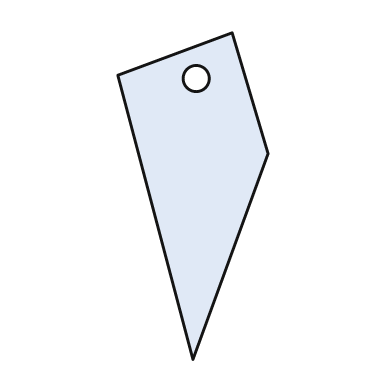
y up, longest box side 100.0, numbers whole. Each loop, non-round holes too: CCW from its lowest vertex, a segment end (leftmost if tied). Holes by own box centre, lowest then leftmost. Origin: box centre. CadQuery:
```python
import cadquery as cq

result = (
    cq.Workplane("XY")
    .moveTo(0.0, -50.0)
    .lineTo(23.0, 13.0)
    .lineTo(12.0, 50.0)
    .lineTo(-23.0, 37.0)
    .close()
    .moveTo(1.0, 36.0)
    .circle(4.0)
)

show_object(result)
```